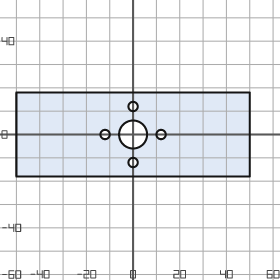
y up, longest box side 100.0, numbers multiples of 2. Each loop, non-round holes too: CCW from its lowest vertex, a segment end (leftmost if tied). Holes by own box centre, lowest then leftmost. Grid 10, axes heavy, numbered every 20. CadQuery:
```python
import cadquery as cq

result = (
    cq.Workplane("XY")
    .moveTo(-50.0, -18.0)
    .lineTo(50.0, -18.0)
    .lineTo(50.0, 18.0)
    .lineTo(-50.0, 18.0)
    .close()
    .moveTo(0.0, -12.0)
    .circle(2.0)
    .moveTo(-12.0, 0.0)
    .circle(2.0)
    .moveTo(0.0, 0.0)
    .circle(6.0)
    .moveTo(12.0, 0.0)
    .circle(2.0)
    .moveTo(0.0, 12.0)
    .circle(2.0)
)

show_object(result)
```